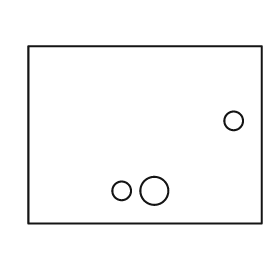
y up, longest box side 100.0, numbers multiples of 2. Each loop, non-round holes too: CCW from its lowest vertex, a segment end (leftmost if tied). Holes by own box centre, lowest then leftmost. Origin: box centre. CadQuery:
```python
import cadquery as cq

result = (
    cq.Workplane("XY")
    .moveTo(-50.0, -38.0)
    .lineTo(50.0, -38.0)
    .lineTo(50.0, 38.0)
    .lineTo(-50.0, 38.0)
    .close()
    .moveTo(-10.0, -24.0)
    .circle(4.0)
    .moveTo(4.0, -24.0)
    .circle(6.0)
    .moveTo(38.0, 6.0)
    .circle(4.0)
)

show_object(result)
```